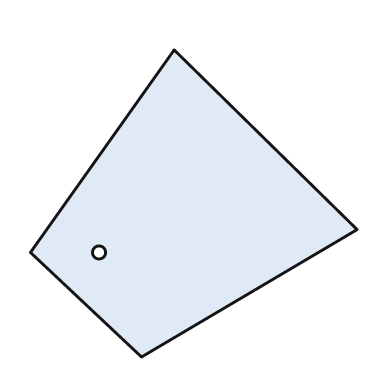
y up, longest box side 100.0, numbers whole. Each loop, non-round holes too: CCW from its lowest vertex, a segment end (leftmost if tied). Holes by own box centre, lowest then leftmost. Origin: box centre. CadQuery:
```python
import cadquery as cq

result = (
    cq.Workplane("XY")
    .moveTo(-16.0, -47.0)
    .lineTo(50.0, -8.0)
    .lineTo(-6.0, 47.0)
    .lineTo(-50.0, -15.0)
    .close()
    .moveTo(-29.0, -15.0)
    .circle(2.0)
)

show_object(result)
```